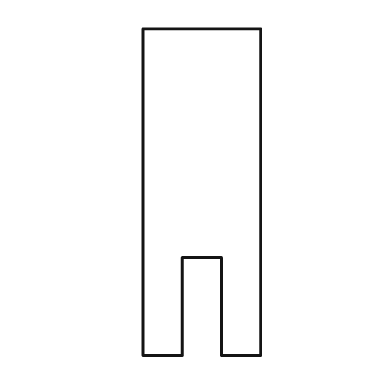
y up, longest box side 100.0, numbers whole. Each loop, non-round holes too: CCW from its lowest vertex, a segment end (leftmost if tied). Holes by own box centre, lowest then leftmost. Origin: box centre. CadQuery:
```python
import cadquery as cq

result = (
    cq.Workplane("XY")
    .moveTo(-18.0, -50.0)
    .lineTo(-6.0, -50.0)
    .lineTo(-6.0, -20.0)
    .lineTo(6.0, -20.0)
    .lineTo(6.0, -50.0)
    .lineTo(18.0, -50.0)
    .lineTo(18.0, 50.0)
    .lineTo(-18.0, 50.0)
    .close()
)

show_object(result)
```